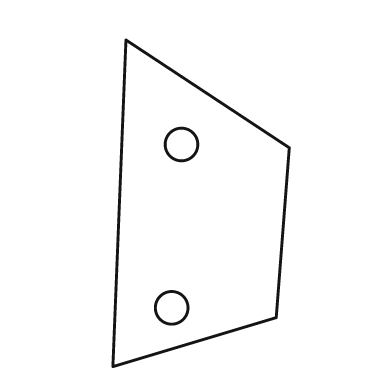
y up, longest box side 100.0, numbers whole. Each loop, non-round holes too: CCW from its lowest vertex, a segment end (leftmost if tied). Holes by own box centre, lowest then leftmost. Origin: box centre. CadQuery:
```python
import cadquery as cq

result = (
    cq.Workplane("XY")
    .moveTo(-27.0, -50.0)
    .lineTo(23.0, -35.0)
    .lineTo(27.0, 17.0)
    .lineTo(-23.0, 50.0)
    .close()
    .moveTo(-9.0, -32.0)
    .circle(5.0)
    .moveTo(-6.0, 18.0)
    .circle(5.0)
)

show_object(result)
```